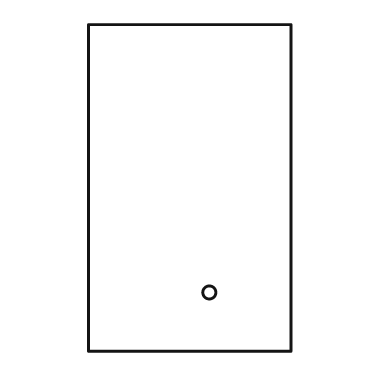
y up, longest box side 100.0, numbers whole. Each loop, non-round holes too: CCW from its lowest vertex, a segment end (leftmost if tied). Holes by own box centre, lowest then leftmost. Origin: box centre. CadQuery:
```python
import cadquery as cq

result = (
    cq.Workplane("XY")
    .moveTo(-31.0, -50.0)
    .lineTo(31.0, -50.0)
    .lineTo(31.0, 50.0)
    .lineTo(-31.0, 50.0)
    .close()
    .moveTo(6.0, -32.0)
    .circle(2.0)
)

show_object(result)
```